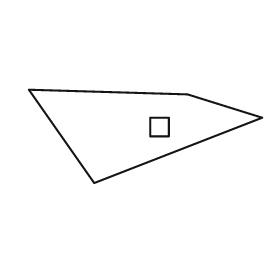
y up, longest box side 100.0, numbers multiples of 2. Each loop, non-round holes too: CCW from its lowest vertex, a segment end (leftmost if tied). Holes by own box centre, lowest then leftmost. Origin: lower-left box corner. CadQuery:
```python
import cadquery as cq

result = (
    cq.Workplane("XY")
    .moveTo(28.0, 0.0)
    .lineTo(100.0, 28.0)
    .lineTo(68.0, 38.0)
    .lineTo(0.0, 40.0)
    .close()
    .moveTo(52.0, 20.0)
    .lineTo(60.0, 20.0)
    .lineTo(60.0, 28.0)
    .lineTo(52.0, 28.0)
    .close()
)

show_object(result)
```